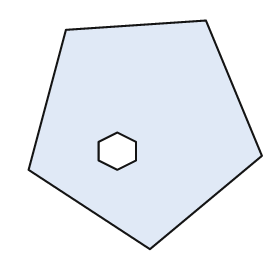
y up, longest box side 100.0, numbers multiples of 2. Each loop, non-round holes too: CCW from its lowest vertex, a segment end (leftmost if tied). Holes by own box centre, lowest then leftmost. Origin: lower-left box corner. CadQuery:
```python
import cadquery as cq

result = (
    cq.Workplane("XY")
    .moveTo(52.0, 0.0)
    .lineTo(100.0, 40.0)
    .lineTo(76.0, 98.0)
    .lineTo(16.0, 94.0)
    .lineTo(0.0, 34.0)
    .close()
    .moveTo(38.0, 34.0)
    .lineTo(46.0, 38.0)
    .lineTo(46.0, 46.0)
    .lineTo(38.0, 50.0)
    .lineTo(30.0, 46.0)
    .lineTo(30.0, 38.0)
    .close()
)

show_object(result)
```